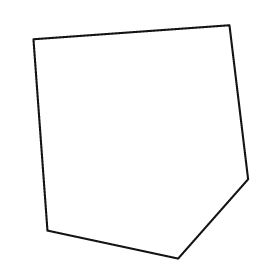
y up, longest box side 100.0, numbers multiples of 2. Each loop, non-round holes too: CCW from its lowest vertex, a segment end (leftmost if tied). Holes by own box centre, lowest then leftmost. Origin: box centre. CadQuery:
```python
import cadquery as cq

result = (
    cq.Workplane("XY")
    .moveTo(16.0, -50.0)
    .lineTo(46.0, -16.0)
    .lineTo(38.0, 50.0)
    .lineTo(-46.0, 44.0)
    .lineTo(-40.0, -38.0)
    .close()
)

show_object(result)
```